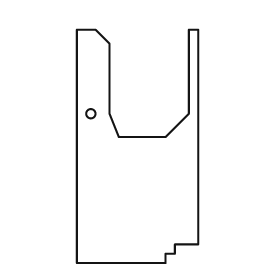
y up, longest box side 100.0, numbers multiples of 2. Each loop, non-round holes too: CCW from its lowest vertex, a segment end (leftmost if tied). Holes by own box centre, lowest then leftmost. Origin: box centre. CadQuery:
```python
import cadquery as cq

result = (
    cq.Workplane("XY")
    .moveTo(-26.0, -50.0)
    .lineTo(12.0, -50.0)
    .lineTo(12.0, -46.0)
    .lineTo(16.0, -46.0)
    .lineTo(16.0, -42.0)
    .lineTo(26.0, -42.0)
    .lineTo(26.0, 50.0)
    .lineTo(22.0, 50.0)
    .lineTo(22.0, 14.0)
    .lineTo(12.0, 4.0)
    .lineTo(-8.0, 4.0)
    .lineTo(-12.0, 14.0)
    .lineTo(-12.0, 44.0)
    .lineTo(-18.0, 50.0)
    .lineTo(-26.0, 50.0)
    .close()
    .moveTo(-20.0, 14.0)
    .circle(2.0)
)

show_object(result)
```